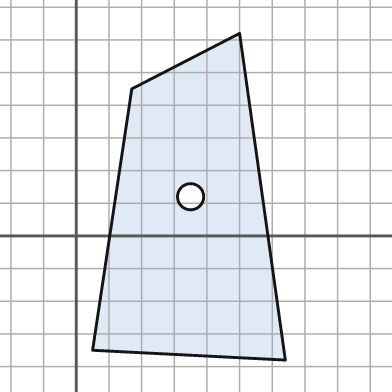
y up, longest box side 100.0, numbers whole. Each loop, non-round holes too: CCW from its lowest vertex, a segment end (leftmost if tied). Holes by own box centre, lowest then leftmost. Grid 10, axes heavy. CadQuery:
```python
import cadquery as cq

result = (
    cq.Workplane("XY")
    .moveTo(64.0, -38.0)
    .lineTo(50.0, 62.0)
    .lineTo(17.0, 45.0)
    .lineTo(5.0, -35.0)
    .close()
    .moveTo(35.0, 12.0)
    .circle(4.0)
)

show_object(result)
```